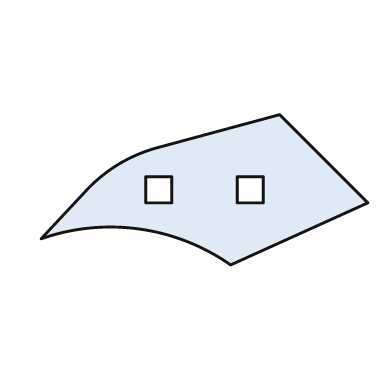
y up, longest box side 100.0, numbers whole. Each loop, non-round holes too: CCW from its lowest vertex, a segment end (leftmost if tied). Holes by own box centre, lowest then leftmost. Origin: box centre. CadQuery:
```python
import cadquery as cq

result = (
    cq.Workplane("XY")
    .moveTo(8.0, -23.0)
    .lineTo(50.0, -4.0)
    .lineTo(23.0, 23.0)
    .lineTo(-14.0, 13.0)
    .threePointArc((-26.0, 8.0), (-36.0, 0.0))
    .lineTo(-50.0, -15.0)
    .threePointArc((-20.0, -12.0), (8.0, -23.0))
    .close()
    .moveTo(-18.0, -4.0)
    .lineTo(-10.0, -4.0)
    .lineTo(-10.0, 4.0)
    .lineTo(-18.0, 4.0)
    .close()
    .moveTo(10.0, -4.0)
    .lineTo(18.0, -4.0)
    .lineTo(18.0, 4.0)
    .lineTo(10.0, 4.0)
    .close()
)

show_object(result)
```